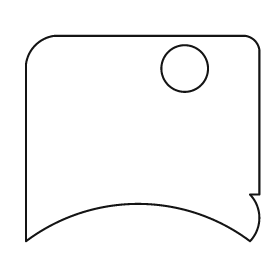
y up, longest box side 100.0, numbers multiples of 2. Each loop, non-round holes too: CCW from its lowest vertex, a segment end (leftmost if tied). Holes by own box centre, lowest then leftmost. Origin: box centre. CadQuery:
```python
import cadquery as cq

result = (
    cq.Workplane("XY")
    .moveTo(-50.0, -44.0)
    .threePointArc((-2.0, -28.0), (46.0, -44.0))
    .threePointArc((50.0, -34.0), (46.0, -24.0))
    .lineTo(50.0, -24.0)
    .lineTo(50.0, 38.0)
    .threePointArc((48.0, 42.0), (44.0, 44.0))
    .lineTo(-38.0, 44.0)
    .threePointArc((-46.0, 40.0), (-50.0, 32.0))
    .close()
    .moveTo(18.0, 30.0)
    .circle(10.0)
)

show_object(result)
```